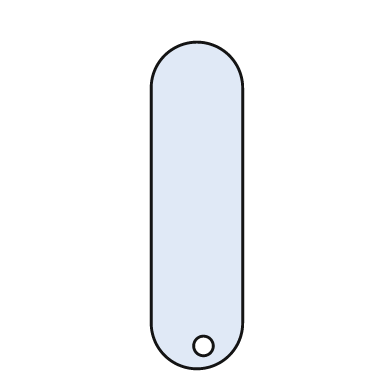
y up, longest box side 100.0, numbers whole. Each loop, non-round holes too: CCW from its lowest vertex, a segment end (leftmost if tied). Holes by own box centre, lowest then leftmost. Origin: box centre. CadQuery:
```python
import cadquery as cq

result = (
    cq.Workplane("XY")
    .moveTo(-14.0, -36.0)
    .threePointArc((0.0, -50.0), (14.0, -36.0))
    .lineTo(14.0, 36.0)
    .threePointArc((0.0, 50.0), (-14.0, 36.0))
    .close()
    .moveTo(2.0, -43.0)
    .circle(3.0)
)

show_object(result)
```